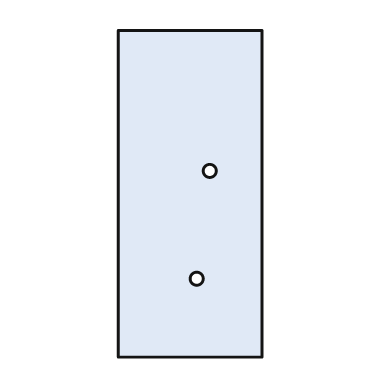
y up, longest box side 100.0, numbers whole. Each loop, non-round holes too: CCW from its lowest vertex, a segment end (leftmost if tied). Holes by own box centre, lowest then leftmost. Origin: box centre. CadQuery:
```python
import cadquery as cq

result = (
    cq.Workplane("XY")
    .moveTo(-22.0, -50.0)
    .lineTo(22.0, -50.0)
    .lineTo(22.0, 50.0)
    .lineTo(-22.0, 50.0)
    .close()
    .moveTo(2.0, -26.0)
    .circle(2.0)
    .moveTo(6.0, 7.0)
    .circle(2.0)
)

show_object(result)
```